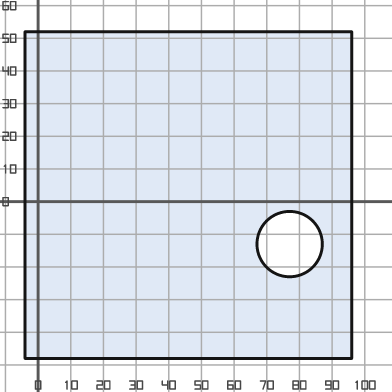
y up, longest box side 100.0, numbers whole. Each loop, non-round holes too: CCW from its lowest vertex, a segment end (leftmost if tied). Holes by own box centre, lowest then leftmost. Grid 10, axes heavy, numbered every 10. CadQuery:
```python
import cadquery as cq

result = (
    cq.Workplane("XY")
    .moveTo(-4.0, -48.0)
    .lineTo(96.0, -48.0)
    .lineTo(96.0, 52.0)
    .lineTo(-4.0, 52.0)
    .close()
    .moveTo(77.0, -13.0)
    .circle(10.0)
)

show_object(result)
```